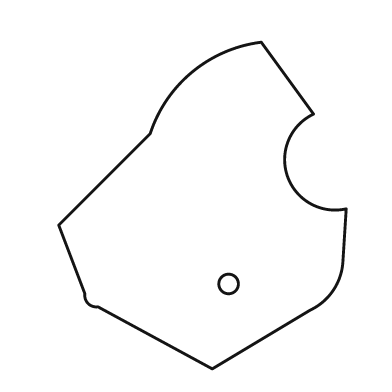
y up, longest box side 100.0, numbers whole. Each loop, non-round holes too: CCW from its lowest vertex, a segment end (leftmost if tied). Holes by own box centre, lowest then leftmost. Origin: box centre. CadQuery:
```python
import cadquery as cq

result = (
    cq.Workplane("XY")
    .moveTo(3.0, -50.0)
    .lineTo(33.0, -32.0)
    .threePointArc((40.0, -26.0), (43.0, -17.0))
    .lineTo(44.0, -1.0)
    .threePointArc((26.0, 9.0), (34.0, 28.0))
    .lineTo(18.0, 50.0)
    .threePointArc((-3.0, 41.0), (-16.0, 22.0))
    .lineTo(-44.0, -6.0)
    .lineTo(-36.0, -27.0)
    .threePointArc((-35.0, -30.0), (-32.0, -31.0))
    .close()
    .moveTo(8.0, -24.0)
    .circle(3.0)
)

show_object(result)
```